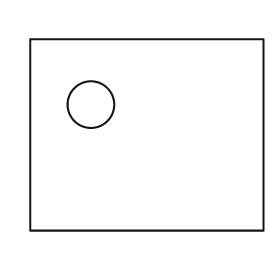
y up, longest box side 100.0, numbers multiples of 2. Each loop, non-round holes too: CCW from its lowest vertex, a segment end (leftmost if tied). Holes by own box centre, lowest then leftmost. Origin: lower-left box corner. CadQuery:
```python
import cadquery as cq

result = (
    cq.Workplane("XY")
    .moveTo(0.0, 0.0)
    .lineTo(100.0, 0.0)
    .lineTo(100.0, 82.0)
    .lineTo(0.0, 82.0)
    .close()
    .moveTo(26.0, 54.0)
    .circle(10.0)
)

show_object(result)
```